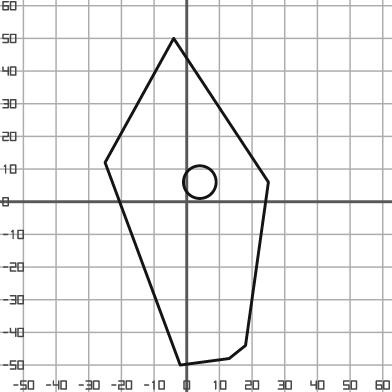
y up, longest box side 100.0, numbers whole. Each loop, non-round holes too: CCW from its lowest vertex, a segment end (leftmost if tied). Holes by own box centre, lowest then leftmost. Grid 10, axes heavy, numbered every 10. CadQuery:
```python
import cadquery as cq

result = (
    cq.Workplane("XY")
    .moveTo(-2.0, -50.0)
    .lineTo(13.0, -48.0)
    .lineTo(18.0, -44.0)
    .lineTo(25.0, 6.0)
    .lineTo(-4.0, 50.0)
    .lineTo(-25.0, 12.0)
    .close()
    .moveTo(4.0, 6.0)
    .circle(5.0)
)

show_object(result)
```